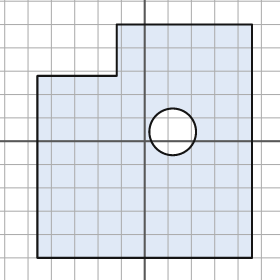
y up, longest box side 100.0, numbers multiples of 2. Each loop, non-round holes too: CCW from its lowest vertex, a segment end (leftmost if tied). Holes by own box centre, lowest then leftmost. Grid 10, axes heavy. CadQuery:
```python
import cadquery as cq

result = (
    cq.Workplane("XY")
    .moveTo(-46.0, -50.0)
    .lineTo(46.0, -50.0)
    .lineTo(46.0, 50.0)
    .lineTo(-12.0, 50.0)
    .lineTo(-12.0, 28.0)
    .lineTo(-46.0, 28.0)
    .close()
    .moveTo(12.0, 4.0)
    .circle(10.0)
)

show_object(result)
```